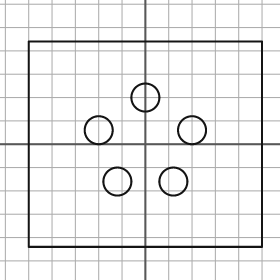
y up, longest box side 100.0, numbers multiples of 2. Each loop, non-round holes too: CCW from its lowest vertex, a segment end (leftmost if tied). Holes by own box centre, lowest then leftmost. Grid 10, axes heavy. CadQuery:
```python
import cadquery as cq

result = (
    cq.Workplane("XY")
    .moveTo(-50.0, -44.0)
    .lineTo(50.0, -44.0)
    .lineTo(50.0, 44.0)
    .lineTo(-50.0, 44.0)
    .close()
    .moveTo(-12.0, -16.0)
    .circle(6.0)
    .moveTo(12.0, -16.0)
    .circle(6.0)
    .moveTo(-20.0, 6.0)
    .circle(6.0)
    .moveTo(20.0, 6.0)
    .circle(6.0)
    .moveTo(0.0, 20.0)
    .circle(6.0)
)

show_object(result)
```